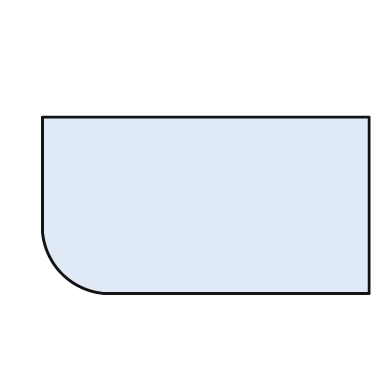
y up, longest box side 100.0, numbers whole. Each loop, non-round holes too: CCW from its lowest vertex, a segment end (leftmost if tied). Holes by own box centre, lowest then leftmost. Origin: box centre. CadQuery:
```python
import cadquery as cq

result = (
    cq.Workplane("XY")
    .moveTo(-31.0, -27.0)
    .lineTo(50.0, -27.0)
    .lineTo(50.0, 27.0)
    .lineTo(-50.0, 27.0)
    .lineTo(-50.0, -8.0)
    .threePointArc((-44.0, -21.0), (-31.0, -27.0))
    .close()
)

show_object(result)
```